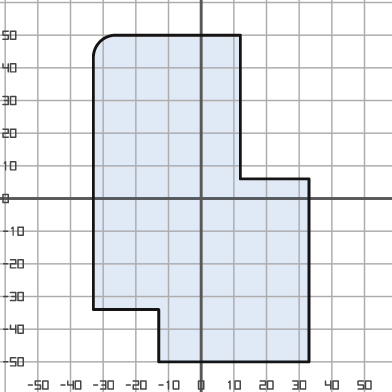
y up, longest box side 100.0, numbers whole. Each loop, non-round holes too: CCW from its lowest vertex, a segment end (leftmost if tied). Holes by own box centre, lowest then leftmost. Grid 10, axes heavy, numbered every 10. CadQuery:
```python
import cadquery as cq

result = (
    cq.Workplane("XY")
    .moveTo(-13.0, -50.0)
    .lineTo(33.0, -50.0)
    .lineTo(33.0, 6.0)
    .lineTo(12.0, 6.0)
    .lineTo(12.0, 50.0)
    .lineTo(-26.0, 50.0)
    .threePointArc((-31.0, 48.0), (-33.0, 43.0))
    .lineTo(-33.0, -34.0)
    .lineTo(-13.0, -34.0)
    .close()
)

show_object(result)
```